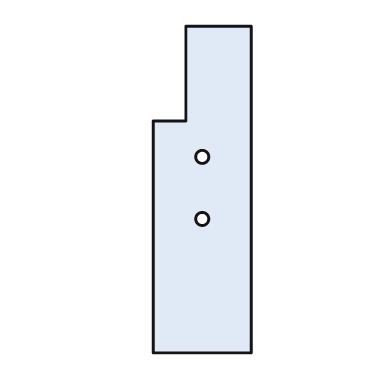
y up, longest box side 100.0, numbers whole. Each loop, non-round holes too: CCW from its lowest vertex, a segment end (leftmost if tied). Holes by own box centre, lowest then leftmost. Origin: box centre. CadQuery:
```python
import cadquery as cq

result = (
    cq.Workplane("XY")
    .moveTo(-15.0, -50.0)
    .lineTo(15.0, -50.0)
    .lineTo(15.0, 50.0)
    .lineTo(-5.0, 50.0)
    .lineTo(-5.0, 21.0)
    .lineTo(-15.0, 21.0)
    .close()
    .moveTo(0.0, -9.0)
    .circle(2.0)
    .moveTo(0.0, 10.0)
    .circle(2.0)
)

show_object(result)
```